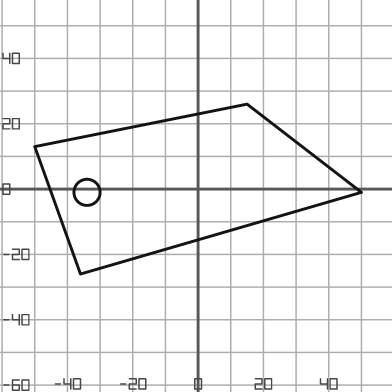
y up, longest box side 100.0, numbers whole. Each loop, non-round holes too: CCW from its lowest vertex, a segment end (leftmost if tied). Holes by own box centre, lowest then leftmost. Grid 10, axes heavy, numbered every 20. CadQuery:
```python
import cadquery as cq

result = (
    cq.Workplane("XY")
    .moveTo(-36.0, -26.0)
    .lineTo(50.0, -1.0)
    .lineTo(15.0, 26.0)
    .lineTo(-50.0, 13.0)
    .close()
    .moveTo(-34.0, -1.0)
    .circle(4.0)
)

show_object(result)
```